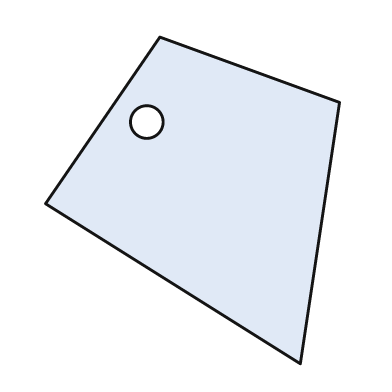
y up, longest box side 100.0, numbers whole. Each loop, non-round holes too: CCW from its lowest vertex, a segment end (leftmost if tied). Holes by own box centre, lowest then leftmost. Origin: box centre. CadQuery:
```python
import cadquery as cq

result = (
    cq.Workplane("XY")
    .moveTo(33.0, -50.0)
    .lineTo(45.0, 30.0)
    .lineTo(-10.0, 50.0)
    .lineTo(-45.0, -1.0)
    .close()
    .moveTo(-14.0, 24.0)
    .circle(5.0)
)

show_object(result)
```